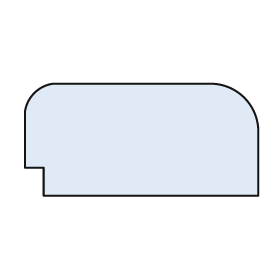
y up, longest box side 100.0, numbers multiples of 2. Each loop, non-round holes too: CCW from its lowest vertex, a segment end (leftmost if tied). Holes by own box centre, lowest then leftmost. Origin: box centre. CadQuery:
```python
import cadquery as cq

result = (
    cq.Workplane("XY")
    .moveTo(-42.0, -24.0)
    .lineTo(50.0, -24.0)
    .lineTo(50.0, 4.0)
    .threePointArc((44.0, 18.0), (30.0, 24.0))
    .lineTo(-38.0, 24.0)
    .threePointArc((-46.0, 20.0), (-50.0, 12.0))
    .lineTo(-50.0, -12.0)
    .lineTo(-42.0, -12.0)
    .close()
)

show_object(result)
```